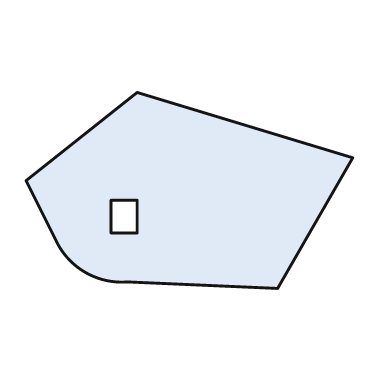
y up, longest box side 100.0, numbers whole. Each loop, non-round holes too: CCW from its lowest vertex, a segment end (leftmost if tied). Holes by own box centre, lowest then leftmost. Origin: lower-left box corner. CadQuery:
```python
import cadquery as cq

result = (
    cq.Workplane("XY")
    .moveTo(77.0, 0.0)
    .lineTo(100.0, 40.0)
    .lineTo(34.0, 60.0)
    .lineTo(0.0, 33.0)
    .lineTo(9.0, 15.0)
    .threePointArc((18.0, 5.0), (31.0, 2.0))
    .close()
    .moveTo(26.0, 17.0)
    .lineTo(34.0, 17.0)
    .lineTo(34.0, 27.0)
    .lineTo(26.0, 27.0)
    .close()
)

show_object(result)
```